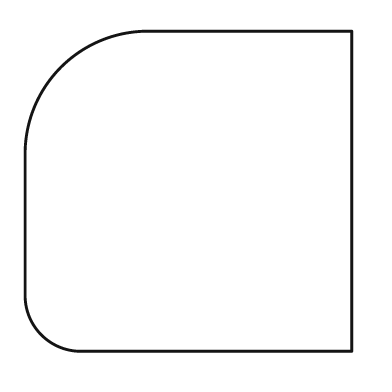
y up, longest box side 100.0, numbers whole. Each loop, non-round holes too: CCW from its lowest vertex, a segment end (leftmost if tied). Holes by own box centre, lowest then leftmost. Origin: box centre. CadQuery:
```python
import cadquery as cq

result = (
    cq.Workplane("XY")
    .moveTo(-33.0, -49.0)
    .lineTo(50.0, -49.0)
    .lineTo(50.0, 49.0)
    .lineTo(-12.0, 49.0)
    .threePointArc((-39.0, 38.0), (-50.0, 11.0))
    .lineTo(-50.0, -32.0)
    .threePointArc((-45.0, -44.0), (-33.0, -49.0))
    .close()
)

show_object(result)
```